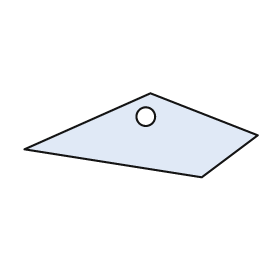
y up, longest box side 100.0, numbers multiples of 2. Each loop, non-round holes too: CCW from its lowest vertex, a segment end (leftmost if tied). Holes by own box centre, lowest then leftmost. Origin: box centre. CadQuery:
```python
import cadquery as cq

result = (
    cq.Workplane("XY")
    .moveTo(26.0, -18.0)
    .lineTo(50.0, 0.0)
    .lineTo(4.0, 18.0)
    .lineTo(-50.0, -6.0)
    .close()
    .moveTo(2.0, 8.0)
    .circle(4.0)
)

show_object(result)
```